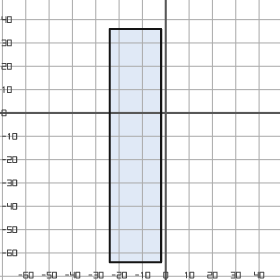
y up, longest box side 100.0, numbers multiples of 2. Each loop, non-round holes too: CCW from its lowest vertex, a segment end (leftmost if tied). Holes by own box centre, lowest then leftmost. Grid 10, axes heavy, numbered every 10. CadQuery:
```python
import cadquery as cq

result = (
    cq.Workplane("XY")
    .moveTo(-24.0, -64.0)
    .lineTo(-2.0, -64.0)
    .lineTo(-2.0, 36.0)
    .lineTo(-24.0, 36.0)
    .close()
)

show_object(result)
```